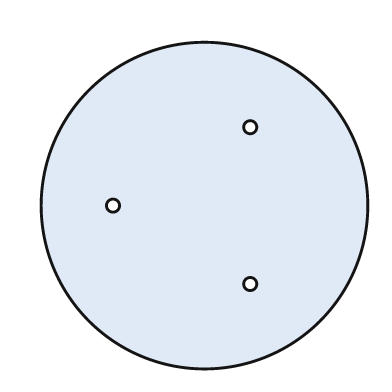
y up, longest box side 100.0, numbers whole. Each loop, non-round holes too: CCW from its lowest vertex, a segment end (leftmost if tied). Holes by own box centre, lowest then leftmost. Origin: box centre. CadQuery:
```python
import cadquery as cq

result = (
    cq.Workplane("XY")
    .moveTo(0.0, 0.0)
    .circle(50.0)
    .moveTo(14.0, -24.0)
    .circle(2.0)
    .moveTo(-28.0, 0.0)
    .circle(2.0)
    .moveTo(14.0, 24.0)
    .circle(2.0)
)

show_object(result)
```